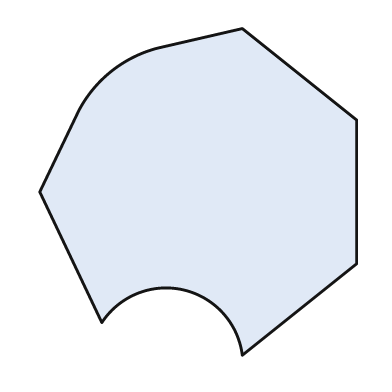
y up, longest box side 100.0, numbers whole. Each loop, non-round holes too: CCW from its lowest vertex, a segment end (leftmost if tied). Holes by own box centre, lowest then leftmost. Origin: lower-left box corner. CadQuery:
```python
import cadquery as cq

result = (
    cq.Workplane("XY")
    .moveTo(62.0, 0.0)
    .lineTo(97.0, 28.0)
    .lineTo(97.0, 72.0)
    .lineTo(62.0, 100.0)
    .lineTo(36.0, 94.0)
    .threePointArc((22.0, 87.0), (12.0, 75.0))
    .lineTo(0.0, 50.0)
    .lineTo(19.0, 10.0)
    .threePointArc((44.0, 20.0), (62.0, 0.0))
    .close()
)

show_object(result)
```